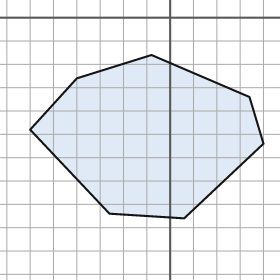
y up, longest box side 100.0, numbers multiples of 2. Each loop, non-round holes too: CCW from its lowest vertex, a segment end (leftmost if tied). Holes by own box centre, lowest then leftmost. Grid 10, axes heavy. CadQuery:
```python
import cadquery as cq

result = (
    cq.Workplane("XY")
    .moveTo(6.0, -86.0)
    .lineTo(40.0, -54.0)
    .lineTo(34.0, -34.0)
    .lineTo(-8.0, -16.0)
    .lineTo(-40.0, -26.0)
    .lineTo(-60.0, -48.0)
    .lineTo(-26.0, -84.0)
    .close()
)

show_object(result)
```